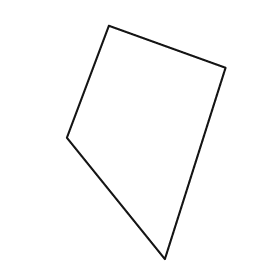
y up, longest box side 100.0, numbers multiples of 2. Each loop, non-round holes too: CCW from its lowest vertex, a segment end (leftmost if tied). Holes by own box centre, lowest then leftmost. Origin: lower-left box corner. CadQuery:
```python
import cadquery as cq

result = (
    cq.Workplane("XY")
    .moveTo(42.0, 0.0)
    .lineTo(68.0, 82.0)
    .lineTo(18.0, 100.0)
    .lineTo(0.0, 52.0)
    .close()
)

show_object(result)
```